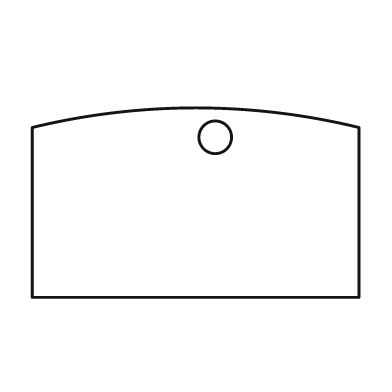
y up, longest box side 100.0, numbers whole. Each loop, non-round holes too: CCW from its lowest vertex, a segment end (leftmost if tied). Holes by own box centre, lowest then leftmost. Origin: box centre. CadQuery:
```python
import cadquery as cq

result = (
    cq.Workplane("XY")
    .moveTo(-50.0, -29.0)
    .lineTo(50.0, -29.0)
    .lineTo(50.0, 23.0)
    .threePointArc((0.0, 29.0), (-50.0, 23.0))
    .close()
    .moveTo(6.0, 20.0)
    .circle(5.0)
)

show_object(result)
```